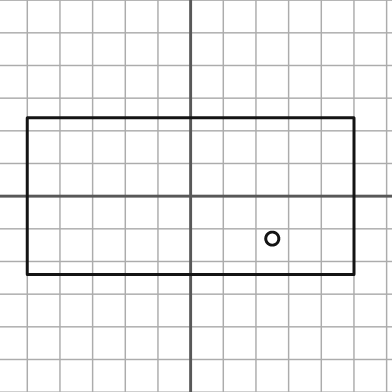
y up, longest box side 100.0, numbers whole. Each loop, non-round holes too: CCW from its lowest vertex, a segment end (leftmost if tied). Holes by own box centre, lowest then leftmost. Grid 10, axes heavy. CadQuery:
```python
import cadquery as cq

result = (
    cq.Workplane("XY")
    .moveTo(-50.0, -24.0)
    .lineTo(50.0, -24.0)
    .lineTo(50.0, 24.0)
    .lineTo(-50.0, 24.0)
    .close()
    .moveTo(25.0, -13.0)
    .circle(2.0)
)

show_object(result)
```